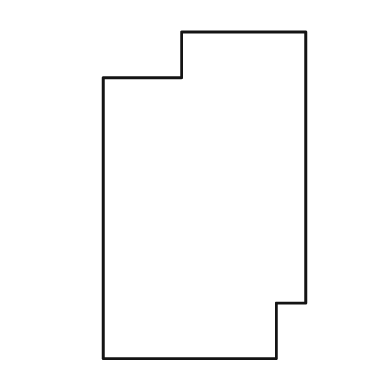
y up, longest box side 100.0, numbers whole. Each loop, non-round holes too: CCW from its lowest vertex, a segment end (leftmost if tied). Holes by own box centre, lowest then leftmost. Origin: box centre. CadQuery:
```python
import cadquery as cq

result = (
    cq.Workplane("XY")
    .moveTo(-31.0, -50.0)
    .lineTo(22.0, -50.0)
    .lineTo(22.0, -33.0)
    .lineTo(31.0, -33.0)
    .lineTo(31.0, 50.0)
    .lineTo(-7.0, 50.0)
    .lineTo(-7.0, 36.0)
    .lineTo(-31.0, 36.0)
    .close()
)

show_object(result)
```